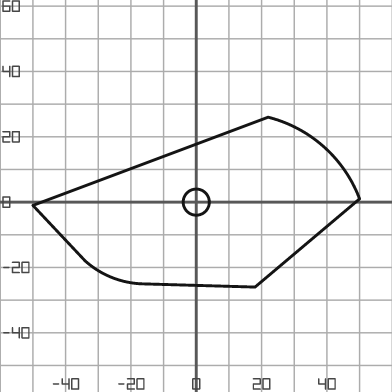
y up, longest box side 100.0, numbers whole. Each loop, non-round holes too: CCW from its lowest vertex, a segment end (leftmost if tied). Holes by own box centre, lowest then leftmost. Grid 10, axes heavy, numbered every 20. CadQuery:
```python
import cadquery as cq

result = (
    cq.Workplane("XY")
    .moveTo(18.0, -26.0)
    .lineTo(50.0, 1.0)
    .threePointArc((39.0, 17.0), (22.0, 26.0))
    .lineTo(-50.0, -1.0)
    .lineTo(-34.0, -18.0)
    .threePointArc((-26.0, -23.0), (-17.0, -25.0))
    .close()
    .moveTo(0.0, 0.0)
    .circle(4.0)
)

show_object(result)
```